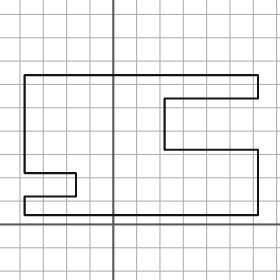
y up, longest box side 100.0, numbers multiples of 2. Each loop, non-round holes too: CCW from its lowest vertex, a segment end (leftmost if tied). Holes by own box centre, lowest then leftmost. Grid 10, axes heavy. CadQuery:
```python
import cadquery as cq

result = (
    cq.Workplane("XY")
    .moveTo(-38.0, 4.0)
    .lineTo(62.0, 4.0)
    .lineTo(62.0, 32.0)
    .lineTo(22.0, 32.0)
    .lineTo(22.0, 54.0)
    .lineTo(62.0, 54.0)
    .lineTo(62.0, 64.0)
    .lineTo(-38.0, 64.0)
    .lineTo(-38.0, 22.0)
    .lineTo(-16.0, 22.0)
    .lineTo(-16.0, 12.0)
    .lineTo(-38.0, 12.0)
    .close()
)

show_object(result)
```